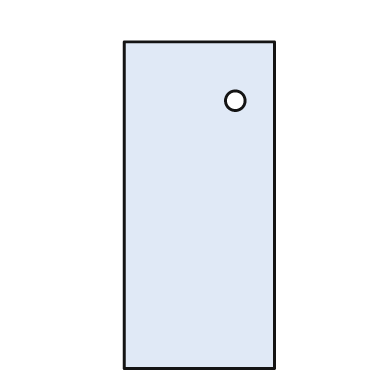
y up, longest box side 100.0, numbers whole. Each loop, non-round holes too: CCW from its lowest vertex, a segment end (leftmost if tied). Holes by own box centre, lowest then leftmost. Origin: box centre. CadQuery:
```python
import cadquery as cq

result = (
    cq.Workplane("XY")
    .moveTo(-23.0, -50.0)
    .lineTo(23.0, -50.0)
    .lineTo(23.0, 50.0)
    .lineTo(-23.0, 50.0)
    .close()
    .moveTo(11.0, 32.0)
    .circle(3.0)
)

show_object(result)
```